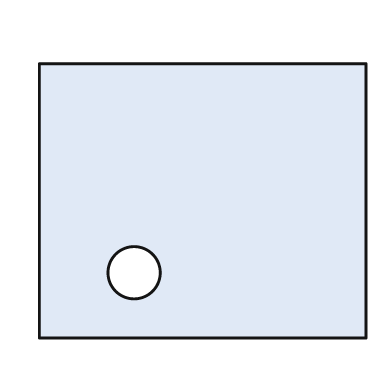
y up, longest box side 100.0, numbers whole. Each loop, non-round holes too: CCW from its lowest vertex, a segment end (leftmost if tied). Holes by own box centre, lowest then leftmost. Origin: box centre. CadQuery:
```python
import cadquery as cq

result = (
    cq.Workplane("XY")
    .moveTo(-50.0, -42.0)
    .lineTo(50.0, -42.0)
    .lineTo(50.0, 42.0)
    .lineTo(-50.0, 42.0)
    .close()
    .moveTo(-21.0, -22.0)
    .circle(8.0)
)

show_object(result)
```